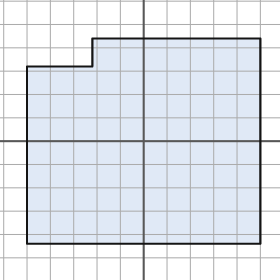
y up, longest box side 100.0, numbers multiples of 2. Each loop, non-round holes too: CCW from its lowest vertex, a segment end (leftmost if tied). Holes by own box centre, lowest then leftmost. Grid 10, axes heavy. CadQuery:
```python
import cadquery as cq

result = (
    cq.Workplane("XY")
    .moveTo(-50.0, -44.0)
    .lineTo(50.0, -44.0)
    .lineTo(50.0, 44.0)
    .lineTo(-22.0, 44.0)
    .lineTo(-22.0, 32.0)
    .lineTo(-50.0, 32.0)
    .close()
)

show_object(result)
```